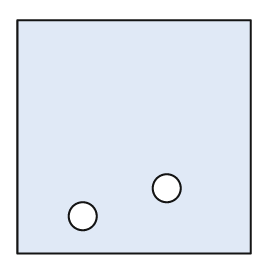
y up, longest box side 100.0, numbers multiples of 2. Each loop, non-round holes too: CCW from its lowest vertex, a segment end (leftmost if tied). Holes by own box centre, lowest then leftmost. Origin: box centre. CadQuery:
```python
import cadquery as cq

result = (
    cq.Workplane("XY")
    .moveTo(-50.0, -50.0)
    .lineTo(50.0, -50.0)
    .lineTo(50.0, 50.0)
    .lineTo(-50.0, 50.0)
    .close()
    .moveTo(-22.0, -34.0)
    .circle(6.0)
    .moveTo(14.0, -22.0)
    .circle(6.0)
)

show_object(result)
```